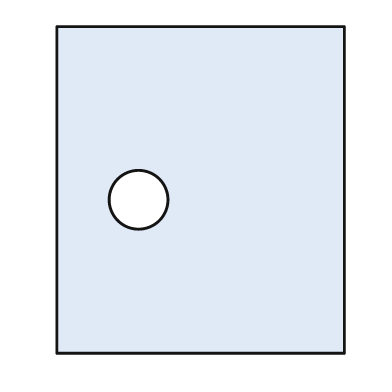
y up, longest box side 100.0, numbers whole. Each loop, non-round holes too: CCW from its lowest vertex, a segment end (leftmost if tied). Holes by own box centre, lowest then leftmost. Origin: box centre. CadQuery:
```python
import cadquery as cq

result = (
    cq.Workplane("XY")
    .moveTo(-44.0, -50.0)
    .lineTo(44.0, -50.0)
    .lineTo(44.0, 50.0)
    .lineTo(-44.0, 50.0)
    .close()
    .moveTo(-19.0, -3.0)
    .circle(9.0)
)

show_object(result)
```